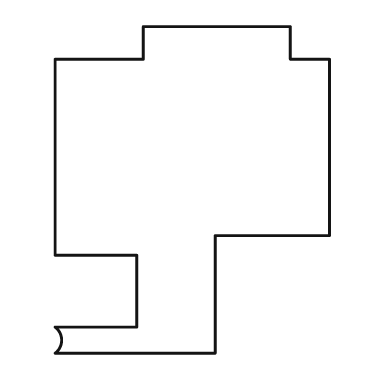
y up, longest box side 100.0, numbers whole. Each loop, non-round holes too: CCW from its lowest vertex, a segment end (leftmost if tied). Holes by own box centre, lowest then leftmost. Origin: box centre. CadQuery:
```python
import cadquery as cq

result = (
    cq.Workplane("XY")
    .moveTo(-42.0, -50.0)
    .lineTo(7.0, -50.0)
    .lineTo(7.0, -14.0)
    .lineTo(42.0, -14.0)
    .lineTo(42.0, 40.0)
    .lineTo(30.0, 40.0)
    .lineTo(30.0, 50.0)
    .lineTo(-15.0, 50.0)
    .lineTo(-15.0, 40.0)
    .lineTo(-42.0, 40.0)
    .lineTo(-42.0, -20.0)
    .lineTo(-17.0, -20.0)
    .lineTo(-17.0, -42.0)
    .lineTo(-42.0, -42.0)
    .threePointArc((-40.0, -46.0), (-42.0, -50.0))
    .close()
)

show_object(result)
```